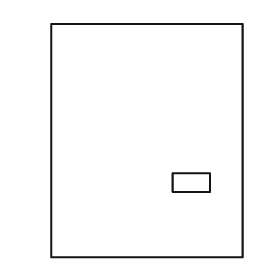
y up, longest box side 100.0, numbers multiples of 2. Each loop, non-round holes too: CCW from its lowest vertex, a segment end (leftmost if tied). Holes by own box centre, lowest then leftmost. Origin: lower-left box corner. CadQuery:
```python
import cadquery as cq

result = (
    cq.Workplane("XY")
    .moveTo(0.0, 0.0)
    .lineTo(82.0, 0.0)
    .lineTo(82.0, 100.0)
    .lineTo(0.0, 100.0)
    .close()
    .moveTo(52.0, 28.0)
    .lineTo(68.0, 28.0)
    .lineTo(68.0, 36.0)
    .lineTo(52.0, 36.0)
    .close()
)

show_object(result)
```